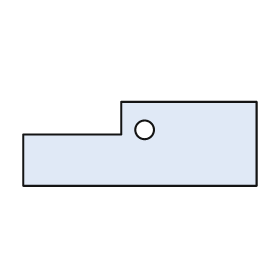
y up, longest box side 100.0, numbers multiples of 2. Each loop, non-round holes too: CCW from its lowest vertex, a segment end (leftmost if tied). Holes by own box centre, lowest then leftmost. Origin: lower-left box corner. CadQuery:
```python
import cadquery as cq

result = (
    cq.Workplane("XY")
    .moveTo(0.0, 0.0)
    .lineTo(100.0, 0.0)
    .lineTo(100.0, 36.0)
    .lineTo(42.0, 36.0)
    .lineTo(42.0, 22.0)
    .lineTo(0.0, 22.0)
    .close()
    .moveTo(52.0, 24.0)
    .circle(4.0)
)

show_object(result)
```